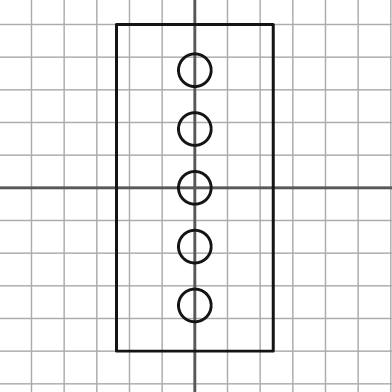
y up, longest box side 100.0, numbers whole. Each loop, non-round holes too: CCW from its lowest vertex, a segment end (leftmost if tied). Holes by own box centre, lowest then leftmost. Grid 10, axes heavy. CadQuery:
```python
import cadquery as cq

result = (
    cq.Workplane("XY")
    .moveTo(-24.0, -50.0)
    .lineTo(24.0, -50.0)
    .lineTo(24.0, 50.0)
    .lineTo(-24.0, 50.0)
    .close()
    .moveTo(0.0, -36.0)
    .circle(5.0)
    .moveTo(0.0, -18.0)
    .circle(5.0)
    .moveTo(0.0, 0.0)
    .circle(5.0)
    .moveTo(0.0, 18.0)
    .circle(5.0)
    .moveTo(0.0, 36.0)
    .circle(5.0)
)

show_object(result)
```